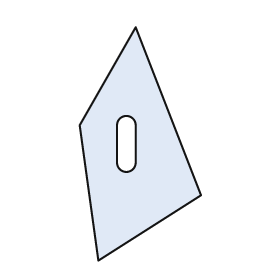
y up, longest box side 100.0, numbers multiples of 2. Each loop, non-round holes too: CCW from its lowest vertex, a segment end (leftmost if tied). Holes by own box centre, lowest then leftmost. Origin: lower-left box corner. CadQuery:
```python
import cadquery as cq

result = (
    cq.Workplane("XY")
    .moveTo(8.0, 0.0)
    .lineTo(52.0, 28.0)
    .lineTo(24.0, 100.0)
    .lineTo(0.0, 58.0)
    .close()
    .moveTo(16.0, 42.0)
    .threePointArc((20.0, 38.0), (24.0, 42.0))
    .lineTo(24.0, 58.0)
    .threePointArc((20.0, 62.0), (16.0, 58.0))
    .close()
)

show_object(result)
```